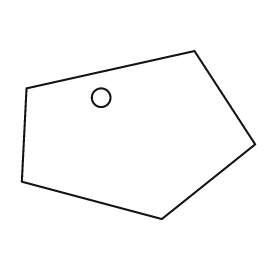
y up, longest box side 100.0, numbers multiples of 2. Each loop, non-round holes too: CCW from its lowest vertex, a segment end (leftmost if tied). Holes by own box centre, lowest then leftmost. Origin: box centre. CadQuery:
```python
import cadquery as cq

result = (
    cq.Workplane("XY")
    .moveTo(10.0, -36.0)
    .lineTo(50.0, -4.0)
    .lineTo(24.0, 36.0)
    .lineTo(-48.0, 20.0)
    .lineTo(-50.0, -20.0)
    .close()
    .moveTo(-16.0, 16.0)
    .circle(4.0)
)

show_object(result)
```